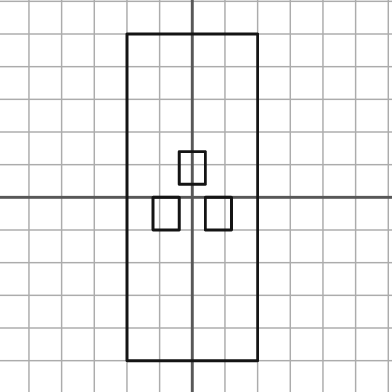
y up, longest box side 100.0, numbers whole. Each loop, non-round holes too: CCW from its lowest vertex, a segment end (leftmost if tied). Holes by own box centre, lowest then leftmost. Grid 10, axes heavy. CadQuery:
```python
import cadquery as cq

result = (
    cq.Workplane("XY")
    .moveTo(-20.0, -50.0)
    .lineTo(20.0, -50.0)
    .lineTo(20.0, 50.0)
    .lineTo(-20.0, 50.0)
    .close()
    .moveTo(-12.0, -10.0)
    .lineTo(-4.0, -10.0)
    .lineTo(-4.0, 0.0)
    .lineTo(-12.0, 0.0)
    .close()
    .moveTo(4.0, -10.0)
    .lineTo(12.0, -10.0)
    .lineTo(12.0, 0.0)
    .lineTo(4.0, 0.0)
    .close()
    .moveTo(-4.0, 4.0)
    .lineTo(4.0, 4.0)
    .lineTo(4.0, 14.0)
    .lineTo(-4.0, 14.0)
    .close()
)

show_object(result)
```